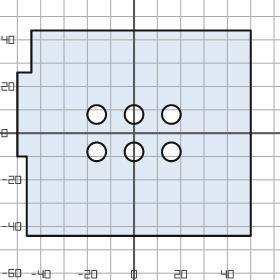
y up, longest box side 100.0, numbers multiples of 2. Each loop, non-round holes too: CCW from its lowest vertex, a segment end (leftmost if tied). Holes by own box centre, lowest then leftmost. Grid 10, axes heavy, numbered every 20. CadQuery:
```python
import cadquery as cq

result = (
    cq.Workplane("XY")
    .moveTo(-46.0, -44.0)
    .lineTo(50.0, -44.0)
    .lineTo(50.0, 44.0)
    .lineTo(-44.0, 44.0)
    .lineTo(-44.0, 26.0)
    .lineTo(-50.0, 26.0)
    .lineTo(-50.0, -10.0)
    .lineTo(-46.0, -10.0)
    .close()
    .moveTo(-16.0, -8.0)
    .circle(4.0)
    .moveTo(0.0, -8.0)
    .circle(4.0)
    .moveTo(16.0, -8.0)
    .circle(4.0)
    .moveTo(-16.0, 8.0)
    .circle(4.0)
    .moveTo(0.0, 8.0)
    .circle(4.0)
    .moveTo(16.0, 8.0)
    .circle(4.0)
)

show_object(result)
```